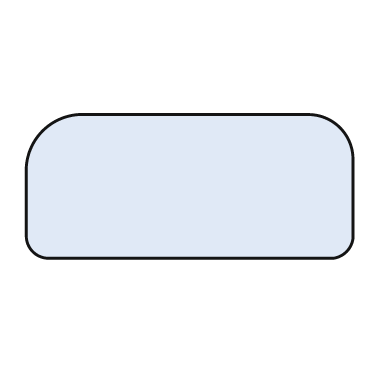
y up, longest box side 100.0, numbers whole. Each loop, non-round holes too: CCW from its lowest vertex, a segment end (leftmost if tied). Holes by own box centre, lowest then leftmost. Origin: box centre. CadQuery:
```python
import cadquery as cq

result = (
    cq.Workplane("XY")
    .moveTo(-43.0, -22.0)
    .lineTo(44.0, -22.0)
    .threePointArc((48.0, -20.0), (50.0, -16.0))
    .lineTo(50.0, 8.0)
    .threePointArc((46.0, 18.0), (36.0, 22.0))
    .lineTo(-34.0, 22.0)
    .threePointArc((-45.0, 17.0), (-50.0, 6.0))
    .lineTo(-50.0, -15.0)
    .threePointArc((-48.0, -20.0), (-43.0, -22.0))
    .close()
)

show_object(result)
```